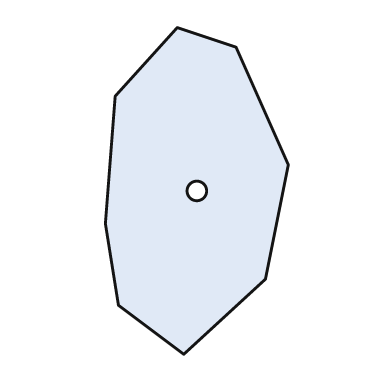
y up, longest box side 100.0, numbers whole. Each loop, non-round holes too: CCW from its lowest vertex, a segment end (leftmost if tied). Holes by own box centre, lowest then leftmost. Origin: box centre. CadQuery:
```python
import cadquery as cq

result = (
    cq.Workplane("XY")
    .moveTo(-4.0, -50.0)
    .lineTo(21.0, -27.0)
    .lineTo(28.0, 8.0)
    .lineTo(12.0, 44.0)
    .lineTo(-6.0, 50.0)
    .lineTo(-25.0, 29.0)
    .lineTo(-28.0, -10.0)
    .lineTo(-24.0, -35.0)
    .close()
    .moveTo(0.0, 0.0)
    .circle(3.0)
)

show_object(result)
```